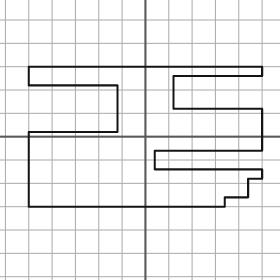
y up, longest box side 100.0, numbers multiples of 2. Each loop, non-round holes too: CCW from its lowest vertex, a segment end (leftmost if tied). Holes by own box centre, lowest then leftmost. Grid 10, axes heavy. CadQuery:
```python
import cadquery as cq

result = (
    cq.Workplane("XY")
    .moveTo(-50.0, -30.0)
    .lineTo(34.0, -30.0)
    .lineTo(34.0, -26.0)
    .lineTo(44.0, -26.0)
    .lineTo(44.0, -18.0)
    .lineTo(50.0, -18.0)
    .lineTo(50.0, -14.0)
    .lineTo(4.0, -14.0)
    .lineTo(4.0, -6.0)
    .lineTo(50.0, -6.0)
    .lineTo(50.0, 12.0)
    .lineTo(12.0, 12.0)
    .lineTo(12.0, 26.0)
    .lineTo(50.0, 26.0)
    .lineTo(50.0, 30.0)
    .lineTo(-50.0, 30.0)
    .lineTo(-50.0, 22.0)
    .lineTo(-12.0, 22.0)
    .lineTo(-12.0, 2.0)
    .lineTo(-50.0, 2.0)
    .close()
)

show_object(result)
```